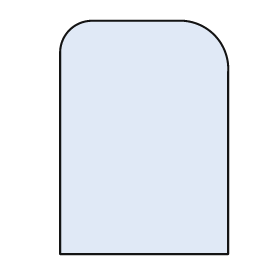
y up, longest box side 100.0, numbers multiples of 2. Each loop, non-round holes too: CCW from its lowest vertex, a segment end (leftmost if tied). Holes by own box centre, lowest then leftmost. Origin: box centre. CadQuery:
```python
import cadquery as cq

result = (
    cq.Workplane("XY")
    .moveTo(-36.0, -50.0)
    .lineTo(36.0, -50.0)
    .lineTo(36.0, 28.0)
    .threePointArc((30.0, 44.0), (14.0, 50.0))
    .lineTo(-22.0, 50.0)
    .threePointArc((-32.0, 46.0), (-36.0, 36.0))
    .close()
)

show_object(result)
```